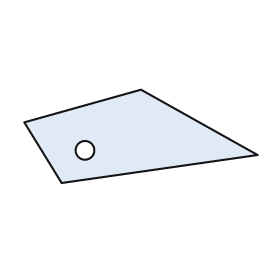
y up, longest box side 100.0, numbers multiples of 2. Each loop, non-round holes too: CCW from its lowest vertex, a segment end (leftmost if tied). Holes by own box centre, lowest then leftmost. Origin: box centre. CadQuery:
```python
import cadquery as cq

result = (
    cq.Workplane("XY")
    .moveTo(-34.0, -20.0)
    .lineTo(50.0, -8.0)
    .lineTo(0.0, 20.0)
    .lineTo(-50.0, 6.0)
    .close()
    .moveTo(-24.0, -6.0)
    .circle(4.0)
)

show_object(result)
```